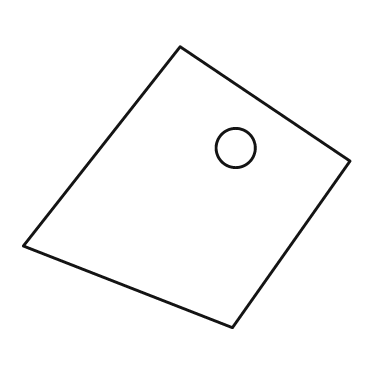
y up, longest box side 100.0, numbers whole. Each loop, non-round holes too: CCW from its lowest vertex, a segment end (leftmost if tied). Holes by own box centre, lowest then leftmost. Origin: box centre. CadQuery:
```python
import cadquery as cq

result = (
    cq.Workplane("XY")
    .moveTo(14.0, -43.0)
    .lineTo(50.0, 8.0)
    .lineTo(-2.0, 43.0)
    .lineTo(-50.0, -18.0)
    .close()
    .moveTo(15.0, 12.0)
    .circle(6.0)
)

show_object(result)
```